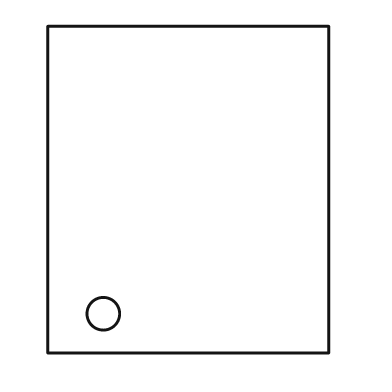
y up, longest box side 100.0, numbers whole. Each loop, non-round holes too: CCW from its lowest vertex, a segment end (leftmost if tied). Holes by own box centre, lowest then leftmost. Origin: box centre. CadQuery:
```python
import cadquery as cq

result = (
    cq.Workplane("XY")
    .moveTo(-43.0, -50.0)
    .lineTo(43.0, -50.0)
    .lineTo(43.0, 50.0)
    .lineTo(-43.0, 50.0)
    .close()
    .moveTo(-26.0, -38.0)
    .circle(5.0)
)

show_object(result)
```